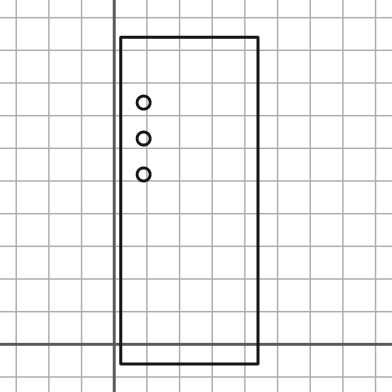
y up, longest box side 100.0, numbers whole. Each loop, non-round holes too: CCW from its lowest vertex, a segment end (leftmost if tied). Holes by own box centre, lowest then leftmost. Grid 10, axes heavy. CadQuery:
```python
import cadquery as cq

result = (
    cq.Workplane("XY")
    .moveTo(2.0, -6.0)
    .lineTo(44.0, -6.0)
    .lineTo(44.0, 94.0)
    .lineTo(2.0, 94.0)
    .close()
    .moveTo(9.0, 52.0)
    .circle(2.0)
    .moveTo(9.0, 63.0)
    .circle(2.0)
    .moveTo(9.0, 74.0)
    .circle(2.0)
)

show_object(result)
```